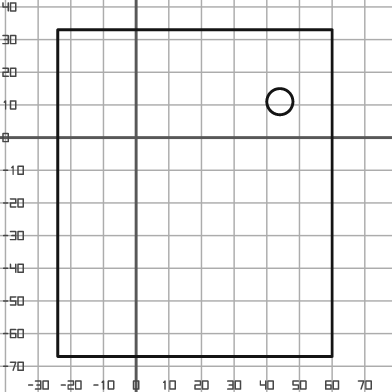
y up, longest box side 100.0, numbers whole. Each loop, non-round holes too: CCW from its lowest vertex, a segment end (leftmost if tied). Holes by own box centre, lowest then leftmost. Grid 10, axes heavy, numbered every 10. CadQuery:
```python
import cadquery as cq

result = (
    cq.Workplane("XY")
    .moveTo(-24.0, -67.0)
    .lineTo(60.0, -67.0)
    .lineTo(60.0, 33.0)
    .lineTo(-24.0, 33.0)
    .close()
    .moveTo(44.0, 11.0)
    .circle(4.0)
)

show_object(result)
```